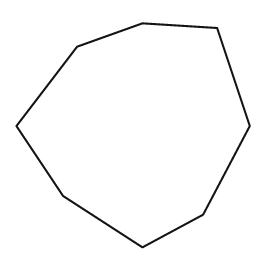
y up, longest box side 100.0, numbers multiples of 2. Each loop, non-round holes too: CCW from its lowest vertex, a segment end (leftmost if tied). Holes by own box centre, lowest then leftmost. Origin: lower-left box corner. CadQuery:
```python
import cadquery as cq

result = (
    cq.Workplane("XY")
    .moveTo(54.0, 0.0)
    .lineTo(80.0, 14.0)
    .lineTo(100.0, 52.0)
    .lineTo(86.0, 94.0)
    .lineTo(54.0, 96.0)
    .lineTo(26.0, 86.0)
    .lineTo(0.0, 52.0)
    .lineTo(20.0, 22.0)
    .close()
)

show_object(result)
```